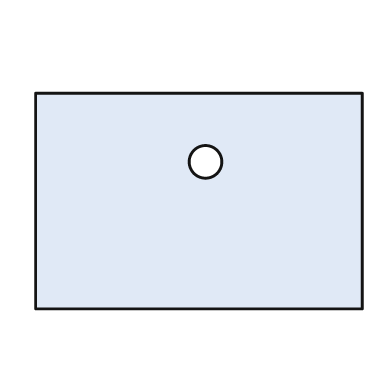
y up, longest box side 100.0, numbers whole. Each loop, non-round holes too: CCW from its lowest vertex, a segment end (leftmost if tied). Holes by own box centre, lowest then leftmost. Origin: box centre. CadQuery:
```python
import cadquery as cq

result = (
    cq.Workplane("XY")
    .moveTo(-50.0, -33.0)
    .lineTo(50.0, -33.0)
    .lineTo(50.0, 33.0)
    .lineTo(-50.0, 33.0)
    .close()
    .moveTo(2.0, 12.0)
    .circle(5.0)
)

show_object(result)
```